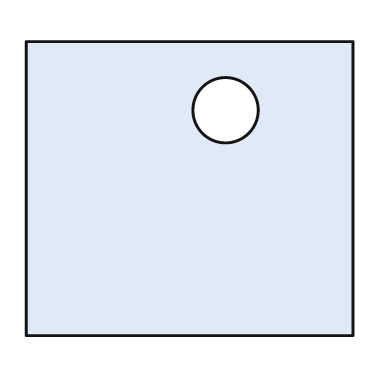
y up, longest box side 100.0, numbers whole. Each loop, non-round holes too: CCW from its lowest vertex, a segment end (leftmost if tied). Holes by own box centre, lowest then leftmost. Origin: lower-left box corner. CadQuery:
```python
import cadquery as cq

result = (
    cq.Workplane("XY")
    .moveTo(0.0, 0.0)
    .lineTo(100.0, 0.0)
    .lineTo(100.0, 90.0)
    .lineTo(0.0, 90.0)
    .close()
    .moveTo(61.0, 69.0)
    .circle(10.0)
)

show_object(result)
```